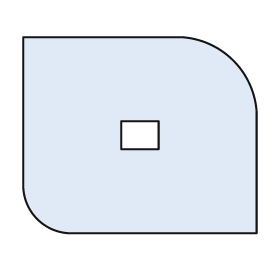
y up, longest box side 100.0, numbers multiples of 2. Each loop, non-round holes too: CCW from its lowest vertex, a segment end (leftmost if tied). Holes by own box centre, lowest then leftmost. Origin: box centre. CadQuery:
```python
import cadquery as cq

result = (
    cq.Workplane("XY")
    .moveTo(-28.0, -42.0)
    .lineTo(50.0, -42.0)
    .lineTo(50.0, 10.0)
    .threePointArc((40.0, 32.0), (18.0, 42.0))
    .lineTo(-50.0, 42.0)
    .lineTo(-50.0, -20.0)
    .threePointArc((-44.0, -36.0), (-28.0, -42.0))
    .close()
    .moveTo(-8.0, -6.0)
    .lineTo(8.0, -6.0)
    .lineTo(8.0, 6.0)
    .lineTo(-8.0, 6.0)
    .close()
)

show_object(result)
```